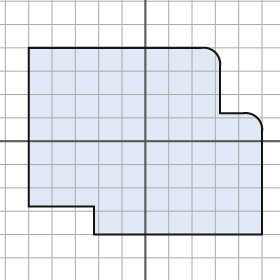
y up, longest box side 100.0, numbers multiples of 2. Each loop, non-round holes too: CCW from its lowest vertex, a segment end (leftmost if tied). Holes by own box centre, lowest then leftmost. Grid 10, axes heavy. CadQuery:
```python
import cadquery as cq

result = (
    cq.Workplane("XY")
    .moveTo(-22.0, -40.0)
    .lineTo(50.0, -40.0)
    .lineTo(50.0, 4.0)
    .threePointArc((48.0, 10.0), (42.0, 12.0))
    .lineTo(32.0, 12.0)
    .lineTo(32.0, 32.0)
    .threePointArc((30.0, 38.0), (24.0, 40.0))
    .lineTo(-50.0, 40.0)
    .lineTo(-50.0, -28.0)
    .lineTo(-22.0, -28.0)
    .close()
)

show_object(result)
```